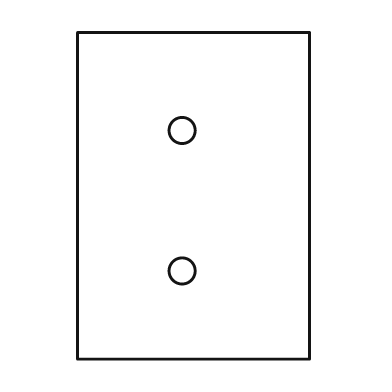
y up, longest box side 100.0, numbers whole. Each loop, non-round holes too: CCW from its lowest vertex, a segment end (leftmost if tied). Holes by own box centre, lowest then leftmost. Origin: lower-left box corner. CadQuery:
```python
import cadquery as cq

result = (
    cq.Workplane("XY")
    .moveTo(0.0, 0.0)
    .lineTo(71.0, 0.0)
    .lineTo(71.0, 100.0)
    .lineTo(0.0, 100.0)
    .close()
    .moveTo(32.0, 27.0)
    .circle(4.0)
    .moveTo(32.0, 70.0)
    .circle(4.0)
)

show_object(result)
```